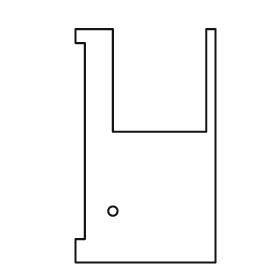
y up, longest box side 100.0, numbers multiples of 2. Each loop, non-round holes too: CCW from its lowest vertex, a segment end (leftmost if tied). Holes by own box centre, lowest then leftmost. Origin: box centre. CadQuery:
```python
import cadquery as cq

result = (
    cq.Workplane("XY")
    .moveTo(-30.0, -50.0)
    .lineTo(30.0, -50.0)
    .lineTo(30.0, 50.0)
    .lineTo(26.0, 50.0)
    .lineTo(26.0, 6.0)
    .lineTo(-14.0, 6.0)
    .lineTo(-14.0, 50.0)
    .lineTo(-30.0, 50.0)
    .lineTo(-30.0, 44.0)
    .lineTo(-26.0, 44.0)
    .lineTo(-26.0, -40.0)
    .lineTo(-30.0, -40.0)
    .close()
    .moveTo(-14.0, -28.0)
    .circle(2.0)
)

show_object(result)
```